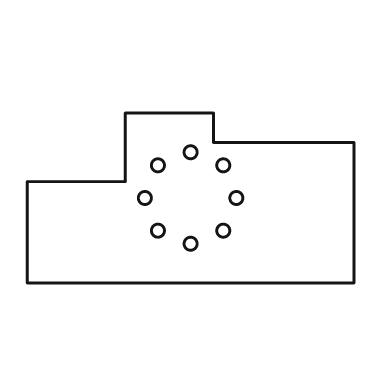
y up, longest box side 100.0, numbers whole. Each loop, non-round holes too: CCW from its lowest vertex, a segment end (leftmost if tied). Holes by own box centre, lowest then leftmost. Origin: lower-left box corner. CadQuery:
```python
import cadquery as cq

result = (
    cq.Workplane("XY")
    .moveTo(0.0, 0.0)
    .lineTo(100.0, 0.0)
    .lineTo(100.0, 43.0)
    .lineTo(57.0, 43.0)
    .lineTo(57.0, 52.0)
    .lineTo(30.0, 52.0)
    .lineTo(30.0, 31.0)
    .lineTo(0.0, 31.0)
    .close()
    .moveTo(50.0, 12.0)
    .circle(2.0)
    .moveTo(40.0, 16.0)
    .circle(2.0)
    .moveTo(60.0, 16.0)
    .circle(2.0)
    .moveTo(36.0, 26.0)
    .circle(2.0)
    .moveTo(64.0, 26.0)
    .circle(2.0)
    .moveTo(40.0, 36.0)
    .circle(2.0)
    .moveTo(60.0, 36.0)
    .circle(2.0)
    .moveTo(50.0, 40.0)
    .circle(2.0)
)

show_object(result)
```